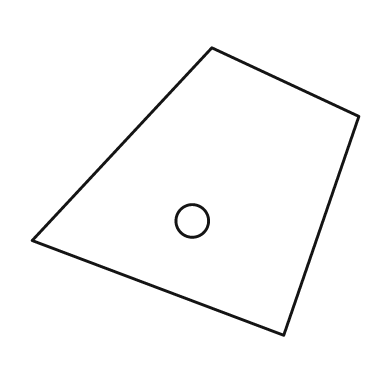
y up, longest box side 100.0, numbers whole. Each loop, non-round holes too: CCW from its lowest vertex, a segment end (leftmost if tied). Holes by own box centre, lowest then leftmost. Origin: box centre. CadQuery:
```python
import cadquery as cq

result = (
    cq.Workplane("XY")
    .moveTo(27.0, -44.0)
    .lineTo(50.0, 23.0)
    .lineTo(5.0, 44.0)
    .lineTo(-50.0, -15.0)
    .close()
    .moveTo(-1.0, -9.0)
    .circle(5.0)
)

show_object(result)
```